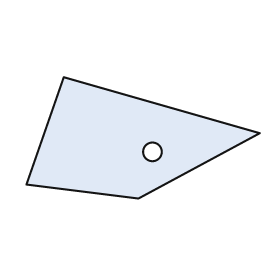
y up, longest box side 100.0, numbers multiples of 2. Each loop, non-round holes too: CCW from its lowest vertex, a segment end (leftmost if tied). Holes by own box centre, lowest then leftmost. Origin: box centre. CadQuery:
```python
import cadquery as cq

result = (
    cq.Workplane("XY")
    .moveTo(-2.0, -26.0)
    .lineTo(50.0, 2.0)
    .lineTo(-34.0, 26.0)
    .lineTo(-50.0, -20.0)
    .close()
    .moveTo(4.0, -6.0)
    .circle(4.0)
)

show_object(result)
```